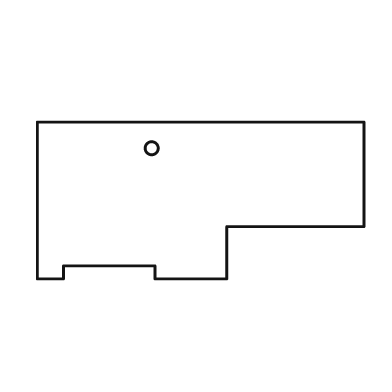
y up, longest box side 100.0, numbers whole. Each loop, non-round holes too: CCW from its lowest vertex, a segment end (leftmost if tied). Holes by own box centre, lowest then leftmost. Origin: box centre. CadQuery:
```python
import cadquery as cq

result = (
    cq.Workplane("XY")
    .moveTo(-50.0, -24.0)
    .lineTo(-42.0, -24.0)
    .lineTo(-42.0, -20.0)
    .lineTo(-14.0, -20.0)
    .lineTo(-14.0, -24.0)
    .lineTo(8.0, -24.0)
    .lineTo(8.0, -8.0)
    .lineTo(50.0, -8.0)
    .lineTo(50.0, 24.0)
    .lineTo(-50.0, 24.0)
    .close()
    .moveTo(-15.0, 16.0)
    .circle(2.0)
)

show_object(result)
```